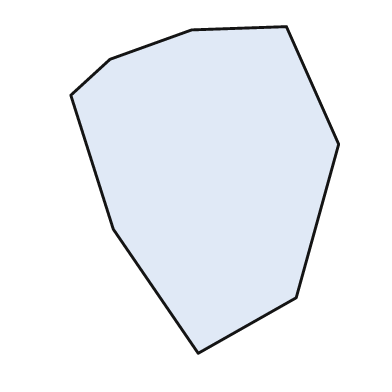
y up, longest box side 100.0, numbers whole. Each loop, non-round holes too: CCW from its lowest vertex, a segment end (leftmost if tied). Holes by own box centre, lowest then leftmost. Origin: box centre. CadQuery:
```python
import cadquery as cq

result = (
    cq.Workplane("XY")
    .moveTo(-2.0, -50.0)
    .lineTo(28.0, -33.0)
    .lineTo(41.0, 14.0)
    .lineTo(25.0, 50.0)
    .lineTo(-4.0, 49.0)
    .lineTo(-29.0, 40.0)
    .lineTo(-41.0, 29.0)
    .lineTo(-28.0, -12.0)
    .close()
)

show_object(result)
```